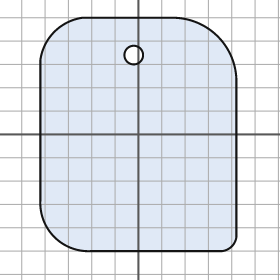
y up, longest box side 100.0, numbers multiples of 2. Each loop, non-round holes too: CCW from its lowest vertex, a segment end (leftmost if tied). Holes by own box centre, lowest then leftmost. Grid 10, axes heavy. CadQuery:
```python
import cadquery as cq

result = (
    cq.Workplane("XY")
    .moveTo(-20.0, -50.0)
    .lineTo(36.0, -50.0)
    .threePointArc((40.0, -48.0), (42.0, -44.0))
    .lineTo(42.0, 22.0)
    .threePointArc((34.0, 42.0), (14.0, 50.0))
    .lineTo(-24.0, 50.0)
    .threePointArc((-36.0, 44.0), (-42.0, 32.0))
    .lineTo(-42.0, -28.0)
    .threePointArc((-36.0, -44.0), (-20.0, -50.0))
    .close()
    .moveTo(-2.0, 34.0)
    .circle(4.0)
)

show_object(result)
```